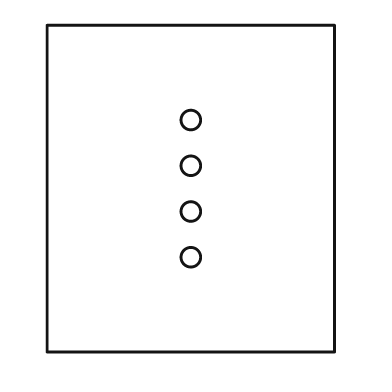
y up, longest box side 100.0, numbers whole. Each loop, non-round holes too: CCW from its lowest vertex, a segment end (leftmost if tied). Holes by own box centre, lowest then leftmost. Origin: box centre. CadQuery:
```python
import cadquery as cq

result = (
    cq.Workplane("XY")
    .moveTo(-44.0, -50.0)
    .lineTo(44.0, -50.0)
    .lineTo(44.0, 50.0)
    .lineTo(-44.0, 50.0)
    .close()
    .moveTo(0.0, -21.0)
    .circle(3.0)
    .moveTo(0.0, -7.0)
    .circle(3.0)
    .moveTo(0.0, 7.0)
    .circle(3.0)
    .moveTo(0.0, 21.0)
    .circle(3.0)
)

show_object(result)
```